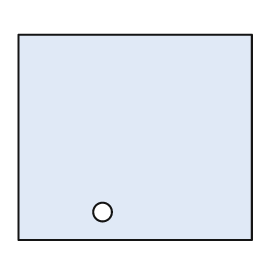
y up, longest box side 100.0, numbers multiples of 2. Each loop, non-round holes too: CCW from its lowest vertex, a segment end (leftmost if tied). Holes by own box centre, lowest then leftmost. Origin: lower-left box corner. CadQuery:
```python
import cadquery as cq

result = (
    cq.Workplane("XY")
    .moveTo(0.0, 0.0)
    .lineTo(100.0, 0.0)
    .lineTo(100.0, 88.0)
    .lineTo(0.0, 88.0)
    .close()
    .moveTo(36.0, 12.0)
    .circle(4.0)
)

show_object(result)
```